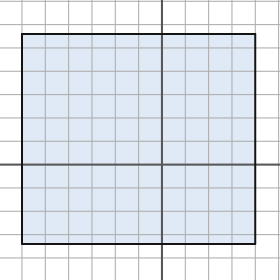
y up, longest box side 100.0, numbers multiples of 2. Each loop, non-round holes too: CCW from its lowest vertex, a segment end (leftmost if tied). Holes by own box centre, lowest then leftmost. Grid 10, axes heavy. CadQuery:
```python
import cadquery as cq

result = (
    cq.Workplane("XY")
    .moveTo(-60.0, -34.0)
    .lineTo(40.0, -34.0)
    .lineTo(40.0, 56.0)
    .lineTo(-60.0, 56.0)
    .close()
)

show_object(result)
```